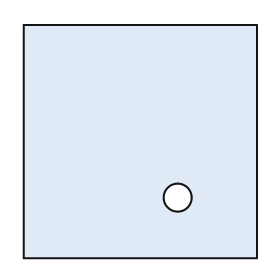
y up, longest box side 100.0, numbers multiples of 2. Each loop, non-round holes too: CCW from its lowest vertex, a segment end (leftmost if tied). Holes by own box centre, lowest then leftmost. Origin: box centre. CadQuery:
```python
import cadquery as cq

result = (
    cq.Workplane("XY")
    .moveTo(-50.0, -50.0)
    .lineTo(50.0, -50.0)
    .lineTo(50.0, 50.0)
    .lineTo(-50.0, 50.0)
    .close()
    .moveTo(16.0, -24.0)
    .circle(6.0)
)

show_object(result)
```